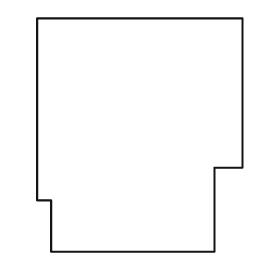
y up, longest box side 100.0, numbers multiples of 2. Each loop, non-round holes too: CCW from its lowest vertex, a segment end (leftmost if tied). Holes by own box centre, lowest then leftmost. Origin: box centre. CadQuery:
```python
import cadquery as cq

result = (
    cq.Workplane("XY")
    .moveTo(-38.0, -50.0)
    .lineTo(32.0, -50.0)
    .lineTo(32.0, -14.0)
    .lineTo(44.0, -14.0)
    .lineTo(44.0, 50.0)
    .lineTo(-44.0, 50.0)
    .lineTo(-44.0, -28.0)
    .lineTo(-38.0, -28.0)
    .close()
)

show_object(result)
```